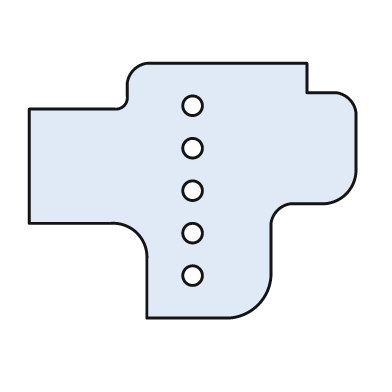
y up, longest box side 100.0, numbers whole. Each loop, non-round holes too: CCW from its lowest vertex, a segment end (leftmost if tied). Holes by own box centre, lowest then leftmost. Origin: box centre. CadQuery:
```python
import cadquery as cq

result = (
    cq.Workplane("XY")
    .moveTo(-14.0, -39.0)
    .lineTo(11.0, -39.0)
    .threePointArc((20.0, -35.0), (24.0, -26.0))
    .lineTo(24.0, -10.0)
    .threePointArc((26.0, -6.0), (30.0, -4.0))
    .lineTo(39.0, -4.0)
    .threePointArc((47.0, -1.0), (50.0, 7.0))
    .lineTo(50.0, 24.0)
    .threePointArc((48.0, 28.0), (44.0, 30.0))
    .lineTo(35.0, 30.0)
    .lineTo(35.0, 39.0)
    .lineTo(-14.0, 39.0)
    .threePointArc((-18.0, 37.0), (-20.0, 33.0))
    .lineTo(-20.0, 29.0)
    .threePointArc((-21.0, 26.0), (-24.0, 25.0))
    .lineTo(-50.0, 25.0)
    .lineTo(-50.0, -10.0)
    .lineTo(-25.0, -10.0)
    .threePointArc((-17.0, -13.0), (-14.0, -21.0))
    .close()
    .moveTo(0.0, -26.0)
    .circle(3.0)
    .moveTo(0.0, -13.0)
    .circle(3.0)
    .moveTo(0.0, 0.0)
    .circle(3.0)
    .moveTo(0.0, 13.0)
    .circle(3.0)
    .moveTo(0.0, 26.0)
    .circle(3.0)
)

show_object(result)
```